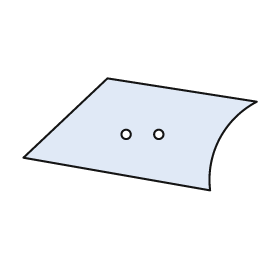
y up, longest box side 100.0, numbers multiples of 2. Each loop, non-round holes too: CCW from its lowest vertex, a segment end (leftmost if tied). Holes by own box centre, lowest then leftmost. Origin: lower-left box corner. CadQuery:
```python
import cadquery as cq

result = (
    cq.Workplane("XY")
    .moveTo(80.0, 0.0)
    .threePointArc((84.0, 22.0), (100.0, 38.0))
    .lineTo(36.0, 48.0)
    .lineTo(0.0, 14.0)
    .close()
    .moveTo(44.0, 24.0)
    .circle(2.0)
    .moveTo(58.0, 24.0)
    .circle(2.0)
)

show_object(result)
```